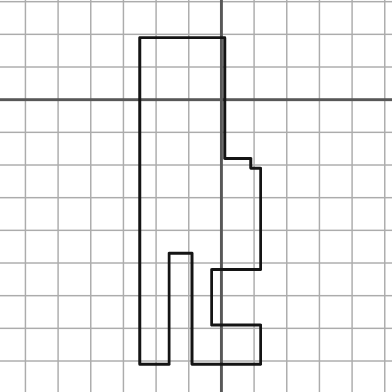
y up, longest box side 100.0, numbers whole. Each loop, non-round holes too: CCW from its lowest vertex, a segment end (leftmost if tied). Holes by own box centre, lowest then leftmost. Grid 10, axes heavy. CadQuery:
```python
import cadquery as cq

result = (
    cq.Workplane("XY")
    .moveTo(-25.0, -81.0)
    .lineTo(-16.0, -81.0)
    .lineTo(-16.0, -47.0)
    .lineTo(-9.0, -47.0)
    .lineTo(-9.0, -81.0)
    .lineTo(12.0, -81.0)
    .lineTo(12.0, -69.0)
    .lineTo(-3.0, -69.0)
    .lineTo(-3.0, -52.0)
    .lineTo(12.0, -52.0)
    .lineTo(12.0, -21.0)
    .lineTo(9.0, -21.0)
    .lineTo(9.0, -18.0)
    .lineTo(1.0, -18.0)
    .lineTo(1.0, 19.0)
    .lineTo(-25.0, 19.0)
    .close()
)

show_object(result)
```